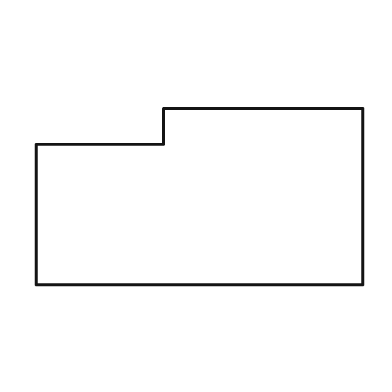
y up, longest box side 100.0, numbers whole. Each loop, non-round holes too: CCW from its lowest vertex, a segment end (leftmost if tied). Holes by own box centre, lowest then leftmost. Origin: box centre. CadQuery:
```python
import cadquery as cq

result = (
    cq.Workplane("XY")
    .moveTo(-50.0, -27.0)
    .lineTo(50.0, -27.0)
    .lineTo(50.0, 27.0)
    .lineTo(-11.0, 27.0)
    .lineTo(-11.0, 16.0)
    .lineTo(-50.0, 16.0)
    .close()
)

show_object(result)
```